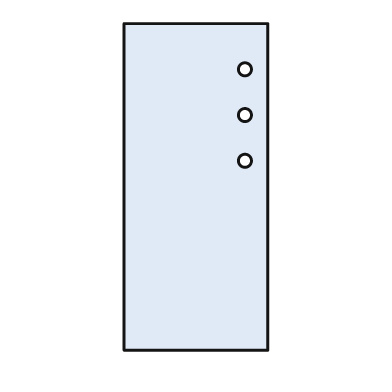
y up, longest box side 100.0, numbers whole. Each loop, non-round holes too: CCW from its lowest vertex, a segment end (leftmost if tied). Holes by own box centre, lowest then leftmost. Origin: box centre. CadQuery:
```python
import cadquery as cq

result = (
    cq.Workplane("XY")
    .moveTo(-22.0, -50.0)
    .lineTo(22.0, -50.0)
    .lineTo(22.0, 50.0)
    .lineTo(-22.0, 50.0)
    .close()
    .moveTo(15.0, 8.0)
    .circle(2.0)
    .moveTo(15.0, 22.0)
    .circle(2.0)
    .moveTo(15.0, 36.0)
    .circle(2.0)
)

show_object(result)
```